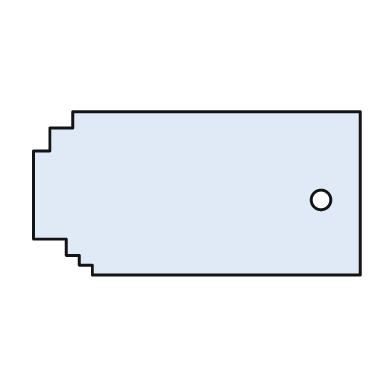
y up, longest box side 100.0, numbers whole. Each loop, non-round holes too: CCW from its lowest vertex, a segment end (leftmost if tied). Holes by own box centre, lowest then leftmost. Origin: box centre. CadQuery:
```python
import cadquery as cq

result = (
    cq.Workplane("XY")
    .moveTo(-32.0, -25.0)
    .lineTo(50.0, -25.0)
    .lineTo(50.0, 25.0)
    .lineTo(-38.0, 25.0)
    .lineTo(-38.0, 20.0)
    .lineTo(-45.0, 20.0)
    .lineTo(-45.0, 13.0)
    .lineTo(-50.0, 13.0)
    .lineTo(-50.0, -14.0)
    .lineTo(-40.0, -14.0)
    .lineTo(-40.0, -19.0)
    .lineTo(-36.0, -19.0)
    .lineTo(-36.0, -22.0)
    .lineTo(-32.0, -22.0)
    .close()
    .moveTo(38.0, -2.0)
    .circle(3.0)
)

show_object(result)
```